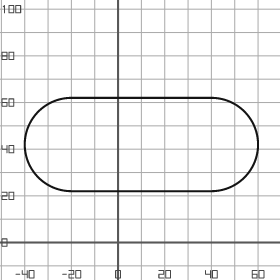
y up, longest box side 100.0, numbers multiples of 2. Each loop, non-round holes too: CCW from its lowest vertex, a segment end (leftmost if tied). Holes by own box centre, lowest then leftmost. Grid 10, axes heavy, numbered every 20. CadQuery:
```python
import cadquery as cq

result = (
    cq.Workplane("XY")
    .moveTo(-20.0, 22.0)
    .lineTo(40.0, 22.0)
    .threePointArc((60.0, 42.0), (40.0, 62.0))
    .lineTo(-20.0, 62.0)
    .threePointArc((-40.0, 42.0), (-20.0, 22.0))
    .close()
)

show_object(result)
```